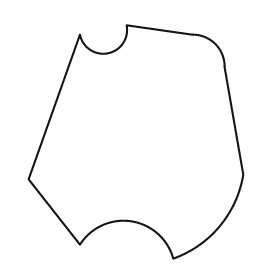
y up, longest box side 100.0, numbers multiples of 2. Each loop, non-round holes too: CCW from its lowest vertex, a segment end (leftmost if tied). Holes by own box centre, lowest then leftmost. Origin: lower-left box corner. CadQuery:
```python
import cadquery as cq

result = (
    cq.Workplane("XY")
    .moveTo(62.0, 0.0)
    .threePointArc((82.0, 14.0), (92.0, 36.0))
    .lineTo(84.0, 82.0)
    .threePointArc((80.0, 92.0), (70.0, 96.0))
    .lineTo(42.0, 100.0)
    .threePointArc((34.0, 88.0), (22.0, 96.0))
    .lineTo(0.0, 34.0)
    .lineTo(22.0, 6.0)
    .threePointArc((44.0, 16.0), (62.0, 0.0))
    .close()
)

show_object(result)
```